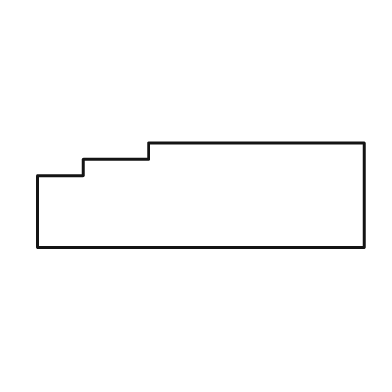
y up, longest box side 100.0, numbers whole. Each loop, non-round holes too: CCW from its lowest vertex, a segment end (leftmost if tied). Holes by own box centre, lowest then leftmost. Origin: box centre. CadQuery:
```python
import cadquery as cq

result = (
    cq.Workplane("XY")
    .moveTo(-50.0, -16.0)
    .lineTo(50.0, -16.0)
    .lineTo(50.0, 16.0)
    .lineTo(-16.0, 16.0)
    .lineTo(-16.0, 11.0)
    .lineTo(-36.0, 11.0)
    .lineTo(-36.0, 6.0)
    .lineTo(-50.0, 6.0)
    .close()
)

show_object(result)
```